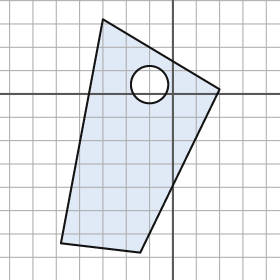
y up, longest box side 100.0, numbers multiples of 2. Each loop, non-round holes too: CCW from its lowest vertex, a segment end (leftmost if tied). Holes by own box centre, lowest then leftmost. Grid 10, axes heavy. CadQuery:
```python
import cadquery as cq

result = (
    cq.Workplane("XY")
    .moveTo(-14.0, -68.0)
    .lineTo(20.0, 2.0)
    .lineTo(-30.0, 32.0)
    .lineTo(-48.0, -64.0)
    .close()
    .moveTo(-10.0, 4.0)
    .circle(8.0)
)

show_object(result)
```